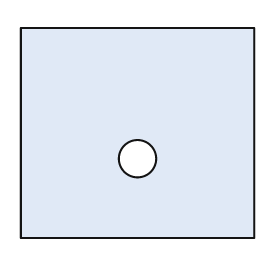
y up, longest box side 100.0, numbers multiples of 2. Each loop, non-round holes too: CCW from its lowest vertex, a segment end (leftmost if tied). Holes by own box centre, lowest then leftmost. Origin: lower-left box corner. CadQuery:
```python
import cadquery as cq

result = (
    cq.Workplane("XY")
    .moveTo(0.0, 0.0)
    .lineTo(100.0, 0.0)
    .lineTo(100.0, 90.0)
    .lineTo(0.0, 90.0)
    .close()
    .moveTo(50.0, 34.0)
    .circle(8.0)
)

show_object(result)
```